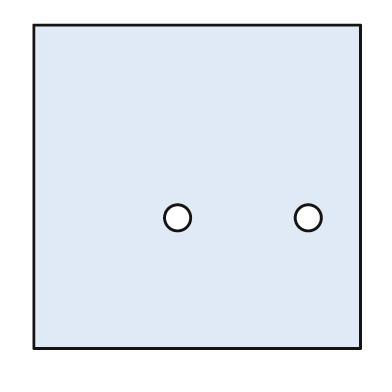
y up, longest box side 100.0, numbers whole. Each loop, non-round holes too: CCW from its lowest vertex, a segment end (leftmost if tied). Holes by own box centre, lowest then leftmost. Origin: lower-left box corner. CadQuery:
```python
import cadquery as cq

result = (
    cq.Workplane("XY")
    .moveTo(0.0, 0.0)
    .lineTo(100.0, 0.0)
    .lineTo(100.0, 99.0)
    .lineTo(0.0, 99.0)
    .close()
    .moveTo(44.0, 40.0)
    .circle(4.0)
    .moveTo(84.0, 40.0)
    .circle(4.0)
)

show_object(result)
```